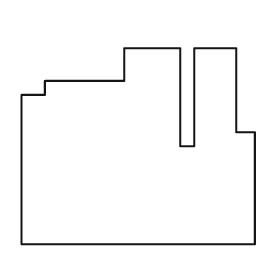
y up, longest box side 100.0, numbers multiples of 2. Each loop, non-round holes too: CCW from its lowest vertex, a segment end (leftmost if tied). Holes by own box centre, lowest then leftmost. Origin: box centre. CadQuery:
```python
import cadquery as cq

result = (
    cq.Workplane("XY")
    .moveTo(-50.0, -42.0)
    .lineTo(50.0, -42.0)
    .lineTo(50.0, 6.0)
    .lineTo(42.0, 6.0)
    .lineTo(42.0, 42.0)
    .lineTo(24.0, 42.0)
    .lineTo(24.0, 0.0)
    .lineTo(18.0, 0.0)
    .lineTo(18.0, 42.0)
    .lineTo(-6.0, 42.0)
    .lineTo(-6.0, 28.0)
    .lineTo(-40.0, 28.0)
    .lineTo(-40.0, 22.0)
    .lineTo(-50.0, 22.0)
    .close()
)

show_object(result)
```